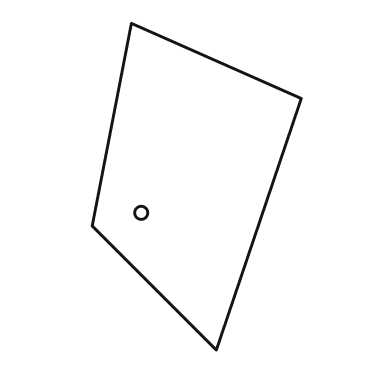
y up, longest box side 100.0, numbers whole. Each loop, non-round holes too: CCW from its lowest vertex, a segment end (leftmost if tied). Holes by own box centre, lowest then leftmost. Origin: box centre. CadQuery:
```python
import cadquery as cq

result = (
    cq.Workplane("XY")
    .moveTo(6.0, -50.0)
    .lineTo(32.0, 27.0)
    .lineTo(-20.0, 50.0)
    .lineTo(-32.0, -12.0)
    .close()
    .moveTo(-17.0, -8.0)
    .circle(2.0)
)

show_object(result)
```